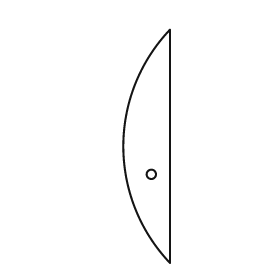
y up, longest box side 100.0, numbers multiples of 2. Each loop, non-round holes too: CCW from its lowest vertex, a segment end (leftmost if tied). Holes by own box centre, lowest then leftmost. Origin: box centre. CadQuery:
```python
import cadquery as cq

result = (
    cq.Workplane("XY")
    .moveTo(10.0, -50.0)
    .lineTo(10.0, 50.0)
    .threePointArc((-10.0, 0.0), (10.0, -50.0))
    .close()
    .moveTo(2.0, -12.0)
    .circle(2.0)
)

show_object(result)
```